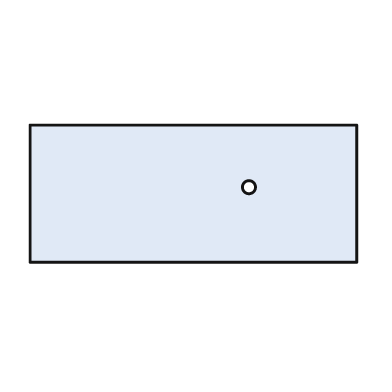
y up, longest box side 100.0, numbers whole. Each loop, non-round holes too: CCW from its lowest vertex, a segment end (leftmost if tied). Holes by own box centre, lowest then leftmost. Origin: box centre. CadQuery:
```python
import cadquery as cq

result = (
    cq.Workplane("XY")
    .moveTo(-50.0, -21.0)
    .lineTo(50.0, -21.0)
    .lineTo(50.0, 21.0)
    .lineTo(-50.0, 21.0)
    .close()
    .moveTo(17.0, 2.0)
    .circle(2.0)
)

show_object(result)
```